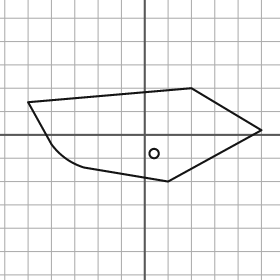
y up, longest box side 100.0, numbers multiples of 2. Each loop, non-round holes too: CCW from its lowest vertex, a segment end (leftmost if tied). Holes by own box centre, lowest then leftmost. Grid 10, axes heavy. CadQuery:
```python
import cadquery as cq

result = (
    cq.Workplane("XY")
    .moveTo(10.0, -20.0)
    .lineTo(50.0, 2.0)
    .lineTo(20.0, 20.0)
    .lineTo(-50.0, 14.0)
    .lineTo(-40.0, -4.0)
    .threePointArc((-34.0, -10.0), (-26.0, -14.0))
    .close()
    .moveTo(4.0, -8.0)
    .circle(2.0)
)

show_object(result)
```